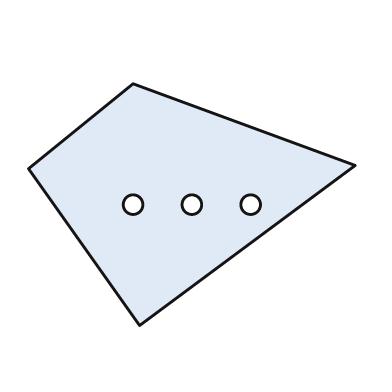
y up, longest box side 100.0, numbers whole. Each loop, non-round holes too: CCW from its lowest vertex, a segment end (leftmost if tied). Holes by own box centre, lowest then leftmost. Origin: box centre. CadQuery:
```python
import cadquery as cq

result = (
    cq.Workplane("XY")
    .moveTo(-16.0, -37.0)
    .lineTo(50.0, 12.0)
    .lineTo(-18.0, 37.0)
    .lineTo(-50.0, 11.0)
    .close()
    .moveTo(-18.0, 0.0)
    .circle(3.0)
    .moveTo(0.0, 0.0)
    .circle(3.0)
    .moveTo(18.0, 0.0)
    .circle(3.0)
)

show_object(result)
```